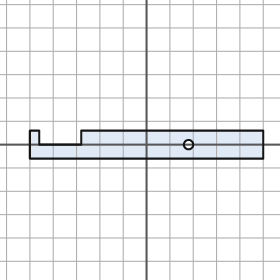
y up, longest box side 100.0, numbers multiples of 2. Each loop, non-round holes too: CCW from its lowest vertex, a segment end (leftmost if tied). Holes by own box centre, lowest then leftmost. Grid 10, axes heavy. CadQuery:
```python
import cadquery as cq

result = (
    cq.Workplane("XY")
    .moveTo(-50.0, -6.0)
    .lineTo(50.0, -6.0)
    .lineTo(50.0, 6.0)
    .lineTo(-28.0, 6.0)
    .lineTo(-28.0, 0.0)
    .lineTo(-46.0, 0.0)
    .lineTo(-46.0, 6.0)
    .lineTo(-50.0, 6.0)
    .close()
    .moveTo(18.0, 0.0)
    .circle(2.0)
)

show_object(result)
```